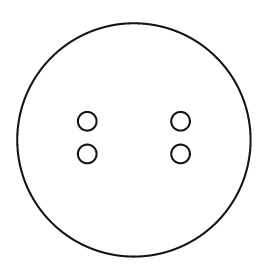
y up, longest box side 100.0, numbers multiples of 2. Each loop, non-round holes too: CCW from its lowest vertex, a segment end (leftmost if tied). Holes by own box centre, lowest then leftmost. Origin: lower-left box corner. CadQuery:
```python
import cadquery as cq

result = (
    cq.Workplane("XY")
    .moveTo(50.0, 50.0)
    .circle(50.0)
    .moveTo(30.0, 44.0)
    .circle(4.0)
    .moveTo(70.0, 44.0)
    .circle(4.0)
    .moveTo(30.0, 58.0)
    .circle(4.0)
    .moveTo(70.0, 58.0)
    .circle(4.0)
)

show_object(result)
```